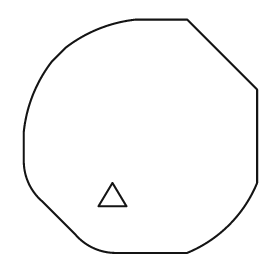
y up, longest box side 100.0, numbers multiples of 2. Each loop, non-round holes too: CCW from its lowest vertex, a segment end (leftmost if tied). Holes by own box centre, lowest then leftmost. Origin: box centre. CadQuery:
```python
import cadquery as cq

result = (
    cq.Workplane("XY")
    .moveTo(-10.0, -50.0)
    .lineTo(20.0, -50.0)
    .threePointArc((38.0, -38.0), (50.0, -20.0))
    .lineTo(50.0, 20.0)
    .lineTo(20.0, 50.0)
    .lineTo(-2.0, 50.0)
    .threePointArc((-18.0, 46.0), (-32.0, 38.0))
    .lineTo(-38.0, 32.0)
    .threePointArc((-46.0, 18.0), (-50.0, 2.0))
    .lineTo(-50.0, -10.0)
    .threePointArc((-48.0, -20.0), (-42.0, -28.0))
    .lineTo(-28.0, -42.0)
    .threePointArc((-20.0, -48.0), (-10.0, -50.0))
    .close()
    .moveTo(-18.0, -30.0)
    .lineTo(-6.0, -30.0)
    .lineTo(-12.0, -20.0)
    .close()
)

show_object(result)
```